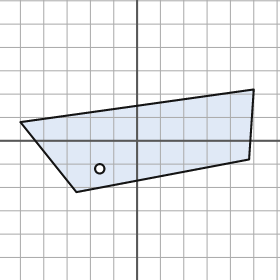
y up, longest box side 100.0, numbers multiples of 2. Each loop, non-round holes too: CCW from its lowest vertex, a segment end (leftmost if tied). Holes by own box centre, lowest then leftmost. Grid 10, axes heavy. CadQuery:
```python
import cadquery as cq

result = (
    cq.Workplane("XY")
    .moveTo(-26.0, -22.0)
    .lineTo(48.0, -8.0)
    .lineTo(50.0, 22.0)
    .lineTo(-50.0, 8.0)
    .close()
    .moveTo(-16.0, -12.0)
    .circle(2.0)
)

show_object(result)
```